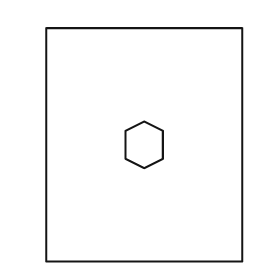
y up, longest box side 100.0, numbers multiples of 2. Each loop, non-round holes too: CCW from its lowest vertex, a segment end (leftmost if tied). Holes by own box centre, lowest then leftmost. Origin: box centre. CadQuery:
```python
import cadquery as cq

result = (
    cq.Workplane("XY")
    .moveTo(-42.0, -50.0)
    .lineTo(42.0, -50.0)
    .lineTo(42.0, 50.0)
    .lineTo(-42.0, 50.0)
    .close()
    .moveTo(0.0, -10.0)
    .lineTo(8.0, -6.0)
    .lineTo(8.0, 6.0)
    .lineTo(0.0, 10.0)
    .lineTo(-8.0, 6.0)
    .lineTo(-8.0, -6.0)
    .close()
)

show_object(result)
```